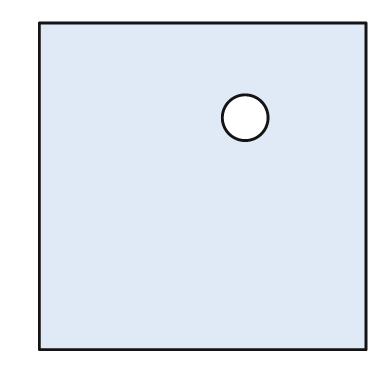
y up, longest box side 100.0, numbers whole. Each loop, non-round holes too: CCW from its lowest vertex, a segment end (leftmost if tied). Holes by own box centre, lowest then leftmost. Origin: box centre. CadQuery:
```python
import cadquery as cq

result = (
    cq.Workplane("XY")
    .moveTo(-50.0, -50.0)
    .lineTo(50.0, -50.0)
    .lineTo(50.0, 50.0)
    .lineTo(-50.0, 50.0)
    .close()
    .moveTo(13.0, 21.0)
    .circle(7.0)
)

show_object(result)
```